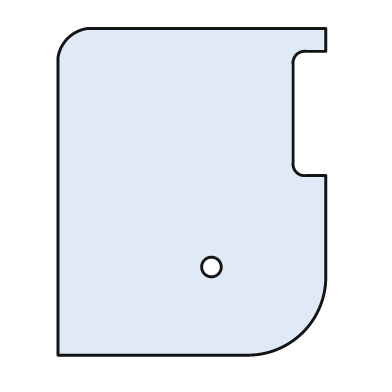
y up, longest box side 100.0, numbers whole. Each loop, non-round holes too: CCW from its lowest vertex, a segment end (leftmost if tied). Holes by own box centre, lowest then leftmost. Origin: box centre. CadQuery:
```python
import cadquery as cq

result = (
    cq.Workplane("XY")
    .moveTo(-41.0, -50.0)
    .lineTo(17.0, -50.0)
    .threePointArc((34.0, -43.0), (41.0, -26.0))
    .lineTo(41.0, 5.0)
    .lineTo(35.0, 5.0)
    .threePointArc((32.0, 6.0), (31.0, 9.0))
    .lineTo(31.0, 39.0)
    .threePointArc((32.0, 42.0), (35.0, 43.0))
    .lineTo(41.0, 43.0)
    .lineTo(41.0, 50.0)
    .lineTo(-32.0, 50.0)
    .threePointArc((-38.0, 47.0), (-41.0, 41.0))
    .close()
    .moveTo(6.0, -23.0)
    .circle(3.0)
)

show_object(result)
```